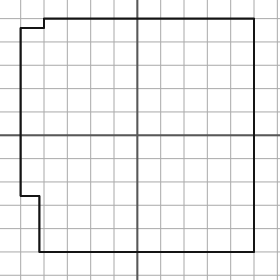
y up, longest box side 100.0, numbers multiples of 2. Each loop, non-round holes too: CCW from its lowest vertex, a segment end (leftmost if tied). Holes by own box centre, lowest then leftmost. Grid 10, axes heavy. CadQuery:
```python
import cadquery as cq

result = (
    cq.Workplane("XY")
    .moveTo(-42.0, -50.0)
    .lineTo(50.0, -50.0)
    .lineTo(50.0, 50.0)
    .lineTo(-40.0, 50.0)
    .lineTo(-40.0, 46.0)
    .lineTo(-50.0, 46.0)
    .lineTo(-50.0, -26.0)
    .lineTo(-42.0, -26.0)
    .close()
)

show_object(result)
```